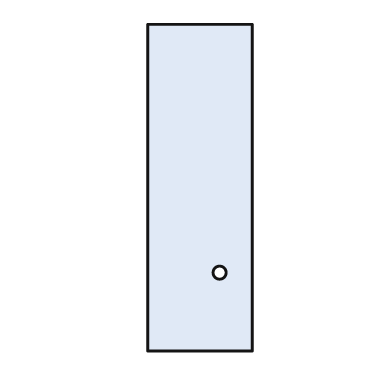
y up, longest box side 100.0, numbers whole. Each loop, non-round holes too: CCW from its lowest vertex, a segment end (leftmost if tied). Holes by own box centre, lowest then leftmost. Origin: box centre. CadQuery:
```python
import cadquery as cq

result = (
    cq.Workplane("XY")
    .moveTo(-16.0, -50.0)
    .lineTo(16.0, -50.0)
    .lineTo(16.0, 50.0)
    .lineTo(-16.0, 50.0)
    .close()
    .moveTo(6.0, -26.0)
    .circle(2.0)
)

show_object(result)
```